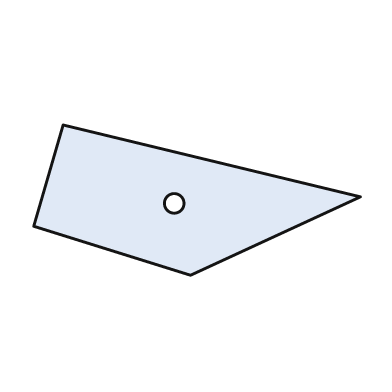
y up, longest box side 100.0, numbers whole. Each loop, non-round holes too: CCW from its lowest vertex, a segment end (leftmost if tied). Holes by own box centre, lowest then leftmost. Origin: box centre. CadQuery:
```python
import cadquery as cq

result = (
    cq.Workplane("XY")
    .moveTo(-2.0, -23.0)
    .lineTo(50.0, 1.0)
    .lineTo(-41.0, 23.0)
    .lineTo(-50.0, -8.0)
    .close()
    .moveTo(-7.0, -1.0)
    .circle(3.0)
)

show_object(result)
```